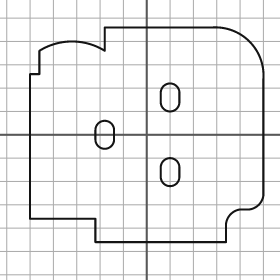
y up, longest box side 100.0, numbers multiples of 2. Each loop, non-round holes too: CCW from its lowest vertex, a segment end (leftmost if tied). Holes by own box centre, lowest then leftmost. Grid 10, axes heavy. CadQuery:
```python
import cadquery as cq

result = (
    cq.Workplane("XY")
    .moveTo(-22.0, -46.0)
    .lineTo(34.0, -46.0)
    .lineTo(34.0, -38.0)
    .threePointArc((36.0, -34.0), (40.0, -32.0))
    .lineTo(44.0, -32.0)
    .threePointArc((48.0, -30.0), (50.0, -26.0))
    .lineTo(50.0, 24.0)
    .threePointArc((44.0, 40.0), (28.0, 46.0))
    .lineTo(-18.0, 46.0)
    .lineTo(-18.0, 36.0)
    .threePointArc((-32.0, 40.0), (-46.0, 36.0))
    .lineTo(-46.0, 26.0)
    .lineTo(-50.0, 26.0)
    .lineTo(-50.0, -36.0)
    .lineTo(-22.0, -36.0)
    .close()
    .moveTo(6.0, -18.0)
    .threePointArc((10.0, -22.0), (14.0, -18.0))
    .lineTo(14.0, -14.0)
    .threePointArc((10.0, -10.0), (6.0, -14.0))
    .close()
    .moveTo(-22.0, -2.0)
    .threePointArc((-18.0, -6.0), (-14.0, -2.0))
    .lineTo(-14.0, 2.0)
    .threePointArc((-18.0, 6.0), (-22.0, 2.0))
    .close()
    .moveTo(6.0, 14.0)
    .threePointArc((10.0, 10.0), (14.0, 14.0))
    .lineTo(14.0, 18.0)
    .threePointArc((10.0, 22.0), (6.0, 18.0))
    .close()
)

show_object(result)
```